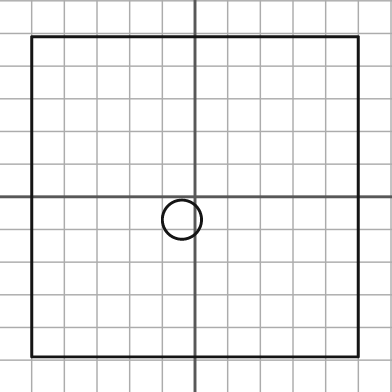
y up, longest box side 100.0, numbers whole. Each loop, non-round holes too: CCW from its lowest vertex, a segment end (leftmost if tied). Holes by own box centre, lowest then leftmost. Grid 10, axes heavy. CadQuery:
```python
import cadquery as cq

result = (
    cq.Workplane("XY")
    .moveTo(-50.0, -49.0)
    .lineTo(50.0, -49.0)
    .lineTo(50.0, 49.0)
    .lineTo(-50.0, 49.0)
    .close()
    .moveTo(-4.0, -7.0)
    .circle(6.0)
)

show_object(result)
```